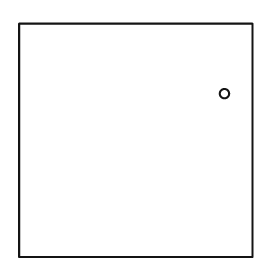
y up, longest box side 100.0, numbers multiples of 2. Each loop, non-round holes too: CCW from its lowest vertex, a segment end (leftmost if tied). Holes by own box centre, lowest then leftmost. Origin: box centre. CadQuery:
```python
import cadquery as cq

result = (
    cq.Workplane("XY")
    .moveTo(-50.0, -50.0)
    .lineTo(50.0, -50.0)
    .lineTo(50.0, 50.0)
    .lineTo(-50.0, 50.0)
    .close()
    .moveTo(38.0, 20.0)
    .circle(2.0)
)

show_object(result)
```